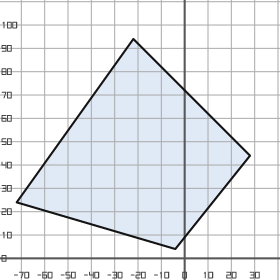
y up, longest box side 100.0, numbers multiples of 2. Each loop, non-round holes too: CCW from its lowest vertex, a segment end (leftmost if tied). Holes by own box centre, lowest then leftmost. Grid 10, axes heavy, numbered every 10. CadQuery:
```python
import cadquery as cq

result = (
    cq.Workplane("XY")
    .moveTo(-4.0, 4.0)
    .lineTo(28.0, 44.0)
    .lineTo(-22.0, 94.0)
    .lineTo(-72.0, 24.0)
    .close()
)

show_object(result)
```